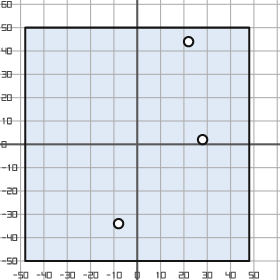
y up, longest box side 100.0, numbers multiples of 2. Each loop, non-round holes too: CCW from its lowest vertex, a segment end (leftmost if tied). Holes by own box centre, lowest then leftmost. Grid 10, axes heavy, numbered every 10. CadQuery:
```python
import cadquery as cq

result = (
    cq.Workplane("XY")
    .moveTo(-48.0, -50.0)
    .lineTo(48.0, -50.0)
    .lineTo(48.0, 50.0)
    .lineTo(-48.0, 50.0)
    .close()
    .moveTo(-8.0, -34.0)
    .circle(2.0)
    .moveTo(28.0, 2.0)
    .circle(2.0)
    .moveTo(22.0, 44.0)
    .circle(2.0)
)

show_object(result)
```